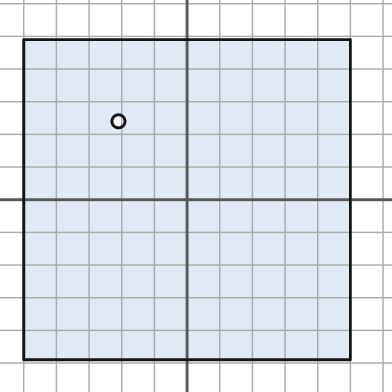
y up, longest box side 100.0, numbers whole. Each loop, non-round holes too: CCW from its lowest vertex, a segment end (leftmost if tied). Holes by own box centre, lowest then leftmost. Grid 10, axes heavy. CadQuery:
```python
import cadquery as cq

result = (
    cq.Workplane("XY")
    .moveTo(-50.0, -49.0)
    .lineTo(50.0, -49.0)
    .lineTo(50.0, 49.0)
    .lineTo(-50.0, 49.0)
    .close()
    .moveTo(-21.0, 24.0)
    .circle(2.0)
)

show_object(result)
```